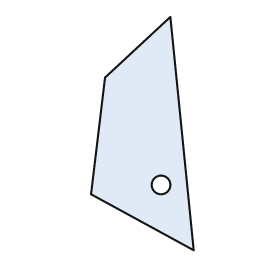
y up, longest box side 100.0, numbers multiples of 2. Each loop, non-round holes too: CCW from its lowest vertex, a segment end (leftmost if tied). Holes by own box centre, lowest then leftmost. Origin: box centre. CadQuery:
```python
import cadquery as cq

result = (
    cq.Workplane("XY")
    .moveTo(22.0, -50.0)
    .lineTo(12.0, 50.0)
    .lineTo(-16.0, 24.0)
    .lineTo(-22.0, -26.0)
    .close()
    .moveTo(8.0, -22.0)
    .circle(4.0)
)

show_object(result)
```